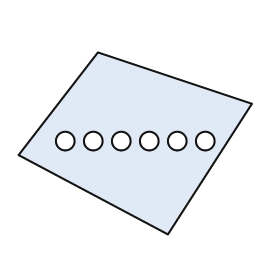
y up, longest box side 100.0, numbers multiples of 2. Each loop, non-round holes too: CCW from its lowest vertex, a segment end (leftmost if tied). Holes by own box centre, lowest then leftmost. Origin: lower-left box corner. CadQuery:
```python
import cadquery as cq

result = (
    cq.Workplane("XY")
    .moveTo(64.0, 0.0)
    .lineTo(100.0, 56.0)
    .lineTo(34.0, 78.0)
    .lineTo(0.0, 34.0)
    .close()
    .moveTo(20.0, 40.0)
    .circle(4.0)
    .moveTo(32.0, 40.0)
    .circle(4.0)
    .moveTo(44.0, 40.0)
    .circle(4.0)
    .moveTo(56.0, 40.0)
    .circle(4.0)
    .moveTo(68.0, 40.0)
    .circle(4.0)
    .moveTo(80.0, 40.0)
    .circle(4.0)
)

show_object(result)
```